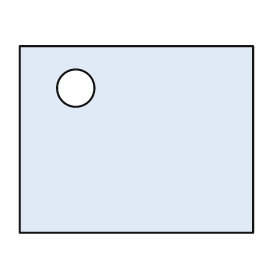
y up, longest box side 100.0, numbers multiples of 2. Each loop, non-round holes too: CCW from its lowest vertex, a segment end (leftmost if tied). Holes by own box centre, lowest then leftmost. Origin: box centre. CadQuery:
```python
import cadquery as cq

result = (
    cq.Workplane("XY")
    .moveTo(-50.0, -40.0)
    .lineTo(50.0, -40.0)
    .lineTo(50.0, 40.0)
    .lineTo(-50.0, 40.0)
    .close()
    .moveTo(-26.0, 22.0)
    .circle(8.0)
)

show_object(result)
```